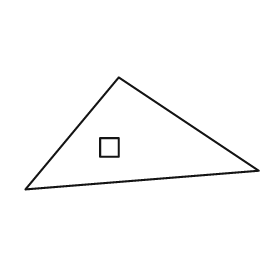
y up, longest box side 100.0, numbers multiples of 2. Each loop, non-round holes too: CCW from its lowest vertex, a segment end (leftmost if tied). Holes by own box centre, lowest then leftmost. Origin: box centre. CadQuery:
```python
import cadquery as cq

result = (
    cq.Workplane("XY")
    .moveTo(-50.0, -24.0)
    .lineTo(50.0, -16.0)
    .lineTo(-10.0, 24.0)
    .close()
    .moveTo(-18.0, -10.0)
    .lineTo(-10.0, -10.0)
    .lineTo(-10.0, -2.0)
    .lineTo(-18.0, -2.0)
    .close()
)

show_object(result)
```